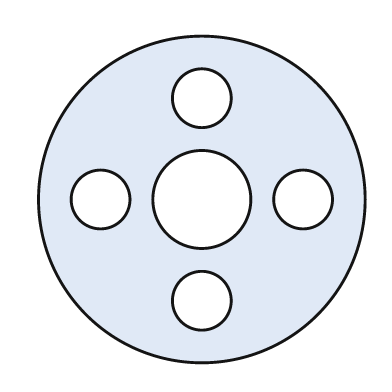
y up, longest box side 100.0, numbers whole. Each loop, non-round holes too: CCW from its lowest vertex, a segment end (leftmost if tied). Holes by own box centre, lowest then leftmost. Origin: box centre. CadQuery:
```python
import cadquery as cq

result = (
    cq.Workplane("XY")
    .moveTo(0.0, 0.0)
    .circle(50.0)
    .moveTo(0.0, -31.0)
    .circle(9.0)
    .moveTo(-31.0, 0.0)
    .circle(9.0)
    .moveTo(0.0, 0.0)
    .circle(15.0)
    .moveTo(31.0, 0.0)
    .circle(9.0)
    .moveTo(0.0, 31.0)
    .circle(9.0)
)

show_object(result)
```